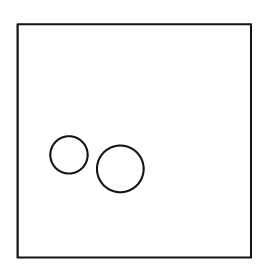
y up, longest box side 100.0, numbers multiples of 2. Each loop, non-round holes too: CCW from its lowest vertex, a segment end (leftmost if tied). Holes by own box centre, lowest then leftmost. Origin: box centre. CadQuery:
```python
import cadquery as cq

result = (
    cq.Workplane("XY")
    .moveTo(-50.0, -50.0)
    .lineTo(50.0, -50.0)
    .lineTo(50.0, 50.0)
    .lineTo(-50.0, 50.0)
    .close()
    .moveTo(-6.0, -12.0)
    .circle(10.0)
    .moveTo(-28.0, -6.0)
    .circle(8.0)
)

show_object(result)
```